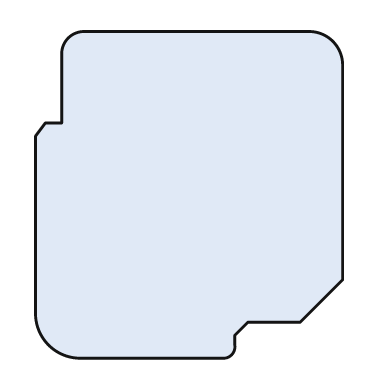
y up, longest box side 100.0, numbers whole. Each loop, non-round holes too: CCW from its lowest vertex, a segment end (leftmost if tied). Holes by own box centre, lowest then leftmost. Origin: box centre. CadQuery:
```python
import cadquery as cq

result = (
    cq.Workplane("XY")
    .moveTo(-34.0, -50.0)
    .lineTo(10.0, -50.0)
    .threePointArc((13.0, -49.0), (14.0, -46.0))
    .lineTo(14.0, -43.0)
    .lineTo(18.0, -39.0)
    .lineTo(34.0, -39.0)
    .lineTo(47.0, -26.0)
    .lineTo(47.0, 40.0)
    .threePointArc((44.0, 47.0), (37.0, 50.0))
    .lineTo(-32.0, 50.0)
    .threePointArc((-37.0, 48.0), (-39.0, 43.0))
    .lineTo(-39.0, 22.0)
    .lineTo(-44.0, 22.0)
    .lineTo(-47.0, 18.0)
    .lineTo(-47.0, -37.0)
    .threePointArc((-43.0, -46.0), (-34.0, -50.0))
    .close()
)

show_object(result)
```